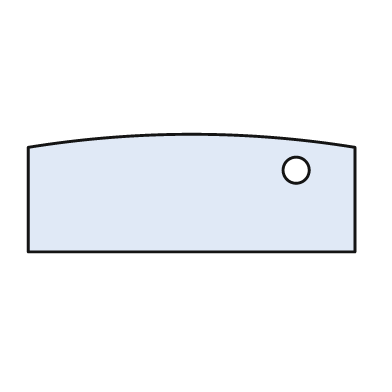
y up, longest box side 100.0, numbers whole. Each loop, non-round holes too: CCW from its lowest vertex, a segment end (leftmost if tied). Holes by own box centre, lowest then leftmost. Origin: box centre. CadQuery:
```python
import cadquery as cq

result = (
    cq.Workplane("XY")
    .moveTo(-50.0, -18.0)
    .lineTo(50.0, -18.0)
    .lineTo(50.0, 14.0)
    .threePointArc((0.0, 18.0), (-50.0, 14.0))
    .close()
    .moveTo(32.0, 7.0)
    .circle(4.0)
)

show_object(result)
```